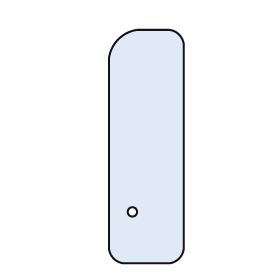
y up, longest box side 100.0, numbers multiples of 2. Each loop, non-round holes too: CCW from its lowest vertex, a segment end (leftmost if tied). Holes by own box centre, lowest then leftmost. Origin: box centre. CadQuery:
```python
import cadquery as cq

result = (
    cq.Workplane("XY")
    .moveTo(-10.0, -50.0)
    .lineTo(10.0, -50.0)
    .threePointArc((14.0, -48.0), (16.0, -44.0))
    .lineTo(16.0, 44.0)
    .threePointArc((14.0, 48.0), (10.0, 50.0))
    .lineTo(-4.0, 50.0)
    .threePointArc((-12.0, 46.0), (-16.0, 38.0))
    .lineTo(-16.0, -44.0)
    .threePointArc((-14.0, -48.0), (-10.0, -50.0))
    .close()
    .moveTo(-6.0, -28.0)
    .circle(2.0)
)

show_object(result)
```